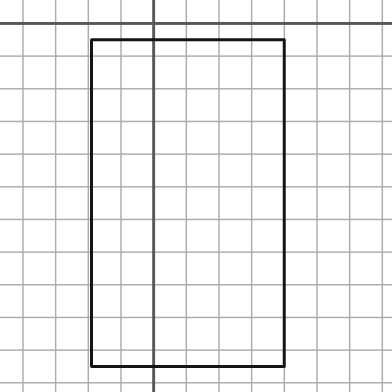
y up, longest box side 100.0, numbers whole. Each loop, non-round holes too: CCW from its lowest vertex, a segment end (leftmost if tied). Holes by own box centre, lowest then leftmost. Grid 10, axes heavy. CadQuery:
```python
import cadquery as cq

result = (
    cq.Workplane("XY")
    .moveTo(-19.0, -105.0)
    .lineTo(40.0, -105.0)
    .lineTo(40.0, -5.0)
    .lineTo(-19.0, -5.0)
    .close()
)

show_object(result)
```